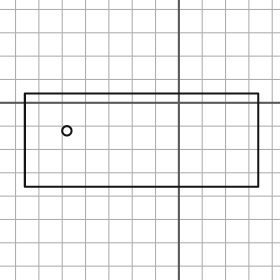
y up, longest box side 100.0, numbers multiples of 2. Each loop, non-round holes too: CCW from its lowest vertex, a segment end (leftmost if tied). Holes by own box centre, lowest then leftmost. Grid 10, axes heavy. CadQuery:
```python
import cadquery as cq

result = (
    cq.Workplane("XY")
    .moveTo(-66.0, -36.0)
    .lineTo(34.0, -36.0)
    .lineTo(34.0, 4.0)
    .lineTo(-66.0, 4.0)
    .close()
    .moveTo(-48.0, -12.0)
    .circle(2.0)
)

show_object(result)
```